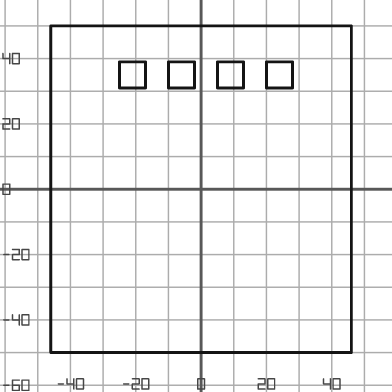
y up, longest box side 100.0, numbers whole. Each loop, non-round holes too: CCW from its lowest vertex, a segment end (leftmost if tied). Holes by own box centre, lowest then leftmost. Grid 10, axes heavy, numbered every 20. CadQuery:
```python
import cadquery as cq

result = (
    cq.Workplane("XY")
    .moveTo(-46.0, -50.0)
    .lineTo(46.0, -50.0)
    .lineTo(46.0, 50.0)
    .lineTo(-46.0, 50.0)
    .close()
    .moveTo(-25.0, 31.0)
    .lineTo(-17.0, 31.0)
    .lineTo(-17.0, 39.0)
    .lineTo(-25.0, 39.0)
    .close()
    .moveTo(-10.0, 31.0)
    .lineTo(-2.0, 31.0)
    .lineTo(-2.0, 39.0)
    .lineTo(-10.0, 39.0)
    .close()
    .moveTo(5.0, 31.0)
    .lineTo(13.0, 31.0)
    .lineTo(13.0, 39.0)
    .lineTo(5.0, 39.0)
    .close()
    .moveTo(20.0, 31.0)
    .lineTo(28.0, 31.0)
    .lineTo(28.0, 39.0)
    .lineTo(20.0, 39.0)
    .close()
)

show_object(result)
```